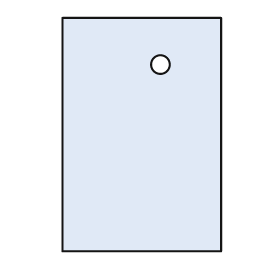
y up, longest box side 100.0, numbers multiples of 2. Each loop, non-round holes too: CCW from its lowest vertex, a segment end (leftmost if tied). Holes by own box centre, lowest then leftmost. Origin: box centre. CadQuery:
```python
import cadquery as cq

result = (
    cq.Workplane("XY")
    .moveTo(-34.0, -50.0)
    .lineTo(34.0, -50.0)
    .lineTo(34.0, 50.0)
    .lineTo(-34.0, 50.0)
    .close()
    .moveTo(8.0, 30.0)
    .circle(4.0)
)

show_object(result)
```